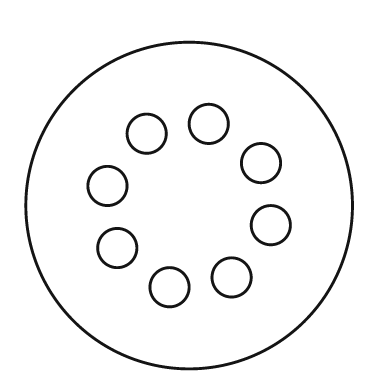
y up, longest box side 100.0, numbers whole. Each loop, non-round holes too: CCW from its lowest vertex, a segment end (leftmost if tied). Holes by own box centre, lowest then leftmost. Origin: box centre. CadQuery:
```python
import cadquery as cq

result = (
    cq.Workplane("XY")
    .moveTo(0.0, 0.0)
    .circle(50.0)
    .moveTo(-6.0, -25.0)
    .circle(6.0)
    .moveTo(13.0, -22.0)
    .circle(6.0)
    .moveTo(-22.0, -13.0)
    .circle(6.0)
    .moveTo(25.0, -6.0)
    .circle(6.0)
    .moveTo(-25.0, 6.0)
    .circle(6.0)
    .moveTo(22.0, 13.0)
    .circle(6.0)
    .moveTo(-13.0, 22.0)
    .circle(6.0)
    .moveTo(6.0, 25.0)
    .circle(6.0)
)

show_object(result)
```